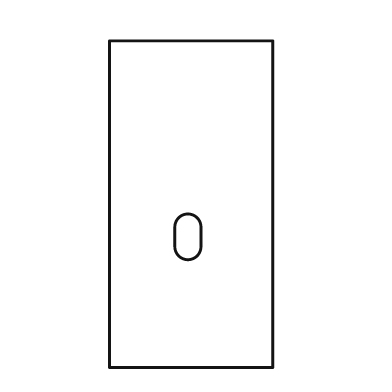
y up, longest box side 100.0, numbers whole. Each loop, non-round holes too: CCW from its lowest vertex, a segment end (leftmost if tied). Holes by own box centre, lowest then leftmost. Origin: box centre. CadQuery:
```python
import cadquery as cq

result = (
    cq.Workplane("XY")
    .moveTo(-25.0, -50.0)
    .lineTo(25.0, -50.0)
    .lineTo(25.0, 50.0)
    .lineTo(-25.0, 50.0)
    .close()
    .moveTo(-5.0, -13.0)
    .threePointArc((-1.0, -17.0), (3.0, -13.0))
    .lineTo(3.0, -7.0)
    .threePointArc((-1.0, -3.0), (-5.0, -7.0))
    .close()
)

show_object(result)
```